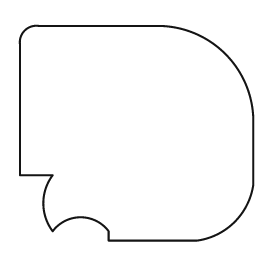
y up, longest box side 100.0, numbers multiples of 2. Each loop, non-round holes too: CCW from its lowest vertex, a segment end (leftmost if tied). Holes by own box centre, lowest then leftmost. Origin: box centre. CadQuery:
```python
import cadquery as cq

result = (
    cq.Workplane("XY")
    .moveTo(-12.0, -46.0)
    .lineTo(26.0, -46.0)
    .threePointArc((42.0, -38.0), (50.0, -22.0))
    .lineTo(50.0, 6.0)
    .threePointArc((38.0, 34.0), (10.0, 46.0))
    .lineTo(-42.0, 46.0)
    .threePointArc((-48.0, 44.0), (-50.0, 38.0))
    .lineTo(-50.0, -18.0)
    .lineTo(-36.0, -18.0)
    .threePointArc((-40.0, -30.0), (-36.0, -42.0))
    .threePointArc((-24.0, -36.0), (-12.0, -42.0))
    .close()
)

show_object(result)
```